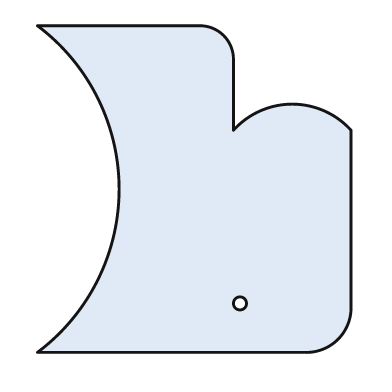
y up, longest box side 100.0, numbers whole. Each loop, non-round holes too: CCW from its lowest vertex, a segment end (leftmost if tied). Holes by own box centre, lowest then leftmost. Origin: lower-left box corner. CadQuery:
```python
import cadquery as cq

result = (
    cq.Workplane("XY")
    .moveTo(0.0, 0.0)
    .lineTo(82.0, 0.0)
    .threePointArc((92.0, 4.0), (96.0, 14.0))
    .lineTo(96.0, 68.0)
    .threePointArc((78.0, 76.0), (60.0, 68.0))
    .lineTo(60.0, 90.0)
    .threePointArc((57.0, 97.0), (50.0, 100.0))
    .lineTo(0.0, 100.0)
    .threePointArc((25.0, 50.0), (0.0, 0.0))
    .close()
    .moveTo(62.0, 15.0)
    .circle(2.0)
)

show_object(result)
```